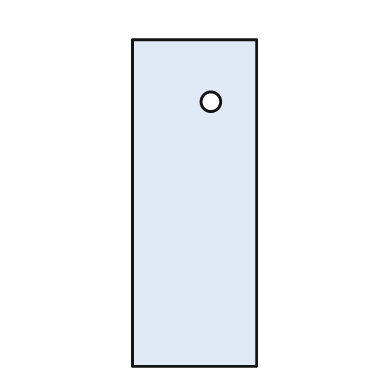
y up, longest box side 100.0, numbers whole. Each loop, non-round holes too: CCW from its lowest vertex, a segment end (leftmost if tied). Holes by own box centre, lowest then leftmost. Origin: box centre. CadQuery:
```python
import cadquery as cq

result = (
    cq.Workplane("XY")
    .moveTo(-19.0, -50.0)
    .lineTo(19.0, -50.0)
    .lineTo(19.0, 50.0)
    .lineTo(-19.0, 50.0)
    .close()
    .moveTo(5.0, 31.0)
    .circle(3.0)
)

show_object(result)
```